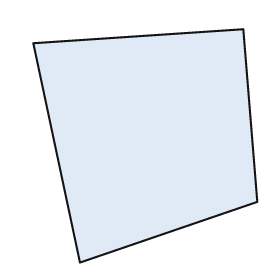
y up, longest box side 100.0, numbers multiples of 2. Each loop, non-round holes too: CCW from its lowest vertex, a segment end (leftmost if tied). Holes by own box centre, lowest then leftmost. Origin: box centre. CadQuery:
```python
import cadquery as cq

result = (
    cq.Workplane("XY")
    .moveTo(-28.0, -50.0)
    .lineTo(48.0, -24.0)
    .lineTo(42.0, 50.0)
    .lineTo(-48.0, 44.0)
    .close()
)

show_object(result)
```